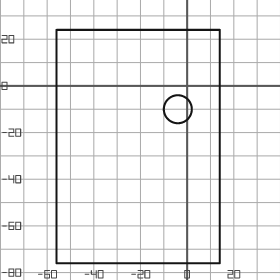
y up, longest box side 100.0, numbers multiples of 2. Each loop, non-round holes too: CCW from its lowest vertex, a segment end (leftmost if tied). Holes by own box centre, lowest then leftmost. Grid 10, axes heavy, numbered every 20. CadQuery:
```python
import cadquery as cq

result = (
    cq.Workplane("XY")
    .moveTo(-56.0, -76.0)
    .lineTo(14.0, -76.0)
    .lineTo(14.0, 24.0)
    .lineTo(-56.0, 24.0)
    .close()
    .moveTo(-4.0, -10.0)
    .circle(6.0)
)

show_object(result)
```